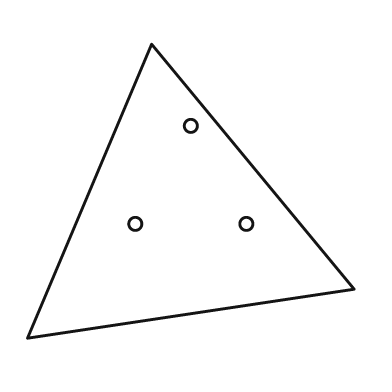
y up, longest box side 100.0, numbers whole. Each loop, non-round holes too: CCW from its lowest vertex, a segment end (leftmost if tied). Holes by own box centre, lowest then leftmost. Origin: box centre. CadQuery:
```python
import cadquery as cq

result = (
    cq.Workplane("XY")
    .moveTo(-50.0, -45.0)
    .lineTo(50.0, -30.0)
    .lineTo(-12.0, 45.0)
    .close()
    .moveTo(-17.0, -10.0)
    .circle(2.0)
    .moveTo(17.0, -10.0)
    .circle(2.0)
    .moveTo(0.0, 20.0)
    .circle(2.0)
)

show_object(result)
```